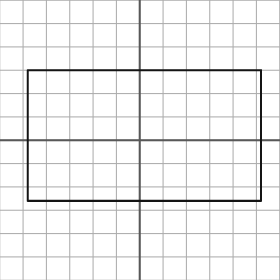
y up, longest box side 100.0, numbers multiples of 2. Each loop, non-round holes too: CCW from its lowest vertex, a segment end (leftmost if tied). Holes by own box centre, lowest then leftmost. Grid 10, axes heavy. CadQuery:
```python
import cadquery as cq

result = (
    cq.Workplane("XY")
    .moveTo(-48.0, -26.0)
    .lineTo(52.0, -26.0)
    .lineTo(52.0, 30.0)
    .lineTo(-48.0, 30.0)
    .close()
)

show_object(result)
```